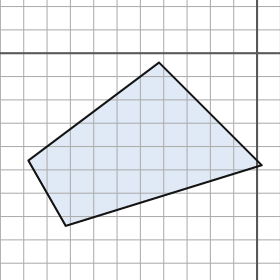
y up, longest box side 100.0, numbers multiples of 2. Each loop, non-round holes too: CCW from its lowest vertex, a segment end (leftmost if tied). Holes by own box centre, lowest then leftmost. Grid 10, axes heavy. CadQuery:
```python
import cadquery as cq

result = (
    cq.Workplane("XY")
    .moveTo(-82.0, -74.0)
    .lineTo(2.0, -48.0)
    .lineTo(-42.0, -4.0)
    .lineTo(-98.0, -46.0)
    .close()
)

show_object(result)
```